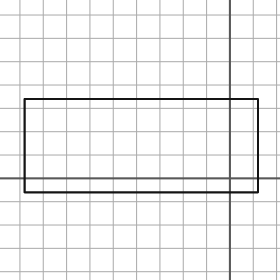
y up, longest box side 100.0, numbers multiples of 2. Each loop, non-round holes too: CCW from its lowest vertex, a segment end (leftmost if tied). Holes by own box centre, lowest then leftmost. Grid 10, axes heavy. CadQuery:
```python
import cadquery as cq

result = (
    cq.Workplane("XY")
    .moveTo(-88.0, -6.0)
    .lineTo(12.0, -6.0)
    .lineTo(12.0, 34.0)
    .lineTo(-88.0, 34.0)
    .close()
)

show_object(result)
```